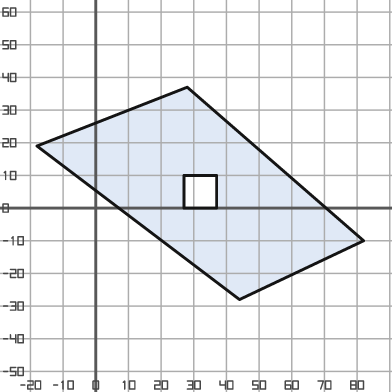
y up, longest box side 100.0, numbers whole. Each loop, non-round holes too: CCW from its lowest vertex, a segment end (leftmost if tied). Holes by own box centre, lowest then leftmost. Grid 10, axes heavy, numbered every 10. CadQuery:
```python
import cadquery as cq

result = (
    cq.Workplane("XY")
    .moveTo(44.0, -28.0)
    .lineTo(82.0, -10.0)
    .lineTo(28.0, 37.0)
    .lineTo(-18.0, 19.0)
    .close()
    .moveTo(27.0, 0.0)
    .lineTo(37.0, 0.0)
    .lineTo(37.0, 10.0)
    .lineTo(27.0, 10.0)
    .close()
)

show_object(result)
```